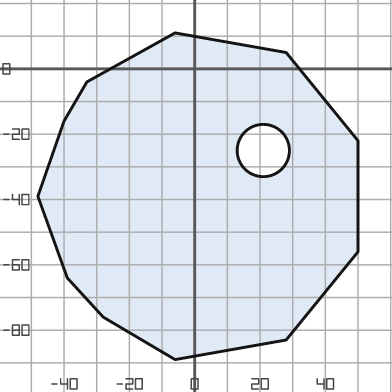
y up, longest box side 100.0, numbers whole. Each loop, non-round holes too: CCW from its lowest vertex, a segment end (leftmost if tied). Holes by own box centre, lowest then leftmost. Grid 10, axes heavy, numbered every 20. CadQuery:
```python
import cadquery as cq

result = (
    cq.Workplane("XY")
    .moveTo(-6.0, -89.0)
    .lineTo(28.0, -83.0)
    .lineTo(50.0, -56.0)
    .lineTo(50.0, -22.0)
    .lineTo(28.0, 5.0)
    .lineTo(-6.0, 11.0)
    .lineTo(-33.0, -4.0)
    .lineTo(-40.0, -16.0)
    .lineTo(-48.0, -39.0)
    .lineTo(-39.0, -64.0)
    .lineTo(-28.0, -76.0)
    .close()
    .moveTo(21.0, -25.0)
    .circle(8.0)
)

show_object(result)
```